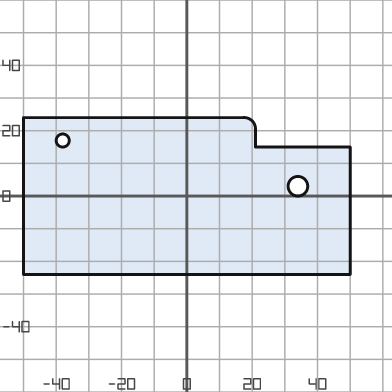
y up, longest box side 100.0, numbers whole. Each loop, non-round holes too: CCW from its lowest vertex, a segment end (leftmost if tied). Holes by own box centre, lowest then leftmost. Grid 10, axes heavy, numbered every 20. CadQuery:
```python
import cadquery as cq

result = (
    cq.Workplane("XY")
    .moveTo(-50.0, -24.0)
    .lineTo(50.0, -24.0)
    .lineTo(50.0, 15.0)
    .lineTo(21.0, 15.0)
    .lineTo(21.0, 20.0)
    .threePointArc((20.0, 23.0), (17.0, 24.0))
    .lineTo(-50.0, 24.0)
    .close()
    .moveTo(34.0, 3.0)
    .circle(3.0)
    .moveTo(-38.0, 17.0)
    .circle(2.0)
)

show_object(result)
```